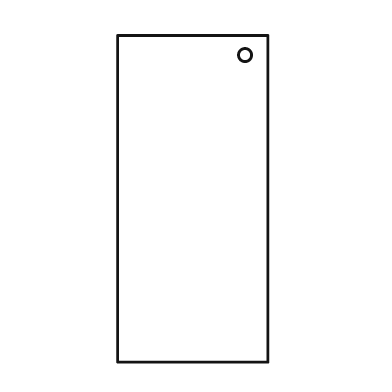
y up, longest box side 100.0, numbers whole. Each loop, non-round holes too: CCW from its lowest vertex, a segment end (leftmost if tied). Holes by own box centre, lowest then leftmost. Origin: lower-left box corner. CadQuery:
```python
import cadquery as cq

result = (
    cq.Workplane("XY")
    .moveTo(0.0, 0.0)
    .lineTo(46.0, 0.0)
    .lineTo(46.0, 100.0)
    .lineTo(0.0, 100.0)
    .close()
    .moveTo(39.0, 94.0)
    .circle(2.0)
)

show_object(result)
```